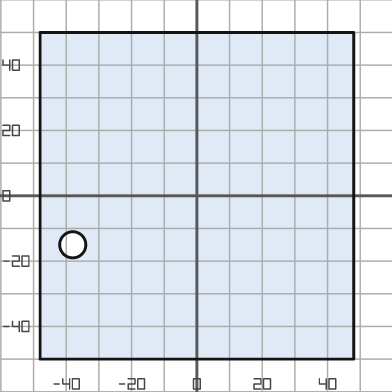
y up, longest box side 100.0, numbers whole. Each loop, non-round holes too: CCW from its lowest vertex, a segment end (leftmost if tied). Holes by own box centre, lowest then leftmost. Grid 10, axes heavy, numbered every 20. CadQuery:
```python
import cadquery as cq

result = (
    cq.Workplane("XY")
    .moveTo(-48.0, -50.0)
    .lineTo(48.0, -50.0)
    .lineTo(48.0, 50.0)
    .lineTo(-48.0, 50.0)
    .close()
    .moveTo(-38.0, -15.0)
    .circle(4.0)
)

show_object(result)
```